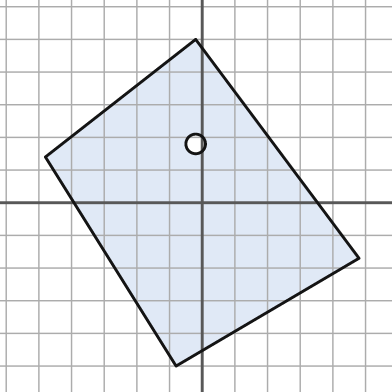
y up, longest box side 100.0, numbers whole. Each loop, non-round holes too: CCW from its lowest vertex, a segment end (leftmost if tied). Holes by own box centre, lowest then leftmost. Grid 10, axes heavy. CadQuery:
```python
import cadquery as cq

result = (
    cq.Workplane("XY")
    .moveTo(-8.0, -50.0)
    .lineTo(48.0, -17.0)
    .lineTo(-2.0, 50.0)
    .lineTo(-48.0, 14.0)
    .close()
    .moveTo(-2.0, 18.0)
    .circle(3.0)
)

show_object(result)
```